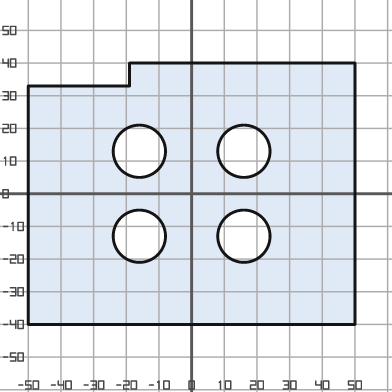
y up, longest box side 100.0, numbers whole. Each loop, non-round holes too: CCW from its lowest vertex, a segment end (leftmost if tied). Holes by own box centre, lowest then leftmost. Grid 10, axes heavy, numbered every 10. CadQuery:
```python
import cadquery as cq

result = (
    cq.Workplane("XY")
    .moveTo(-50.0, -40.0)
    .lineTo(50.0, -40.0)
    .lineTo(50.0, 40.0)
    .lineTo(-19.0, 40.0)
    .lineTo(-19.0, 33.0)
    .lineTo(-50.0, 33.0)
    .close()
    .moveTo(-16.0, -13.0)
    .circle(8.0)
    .moveTo(16.0, -13.0)
    .circle(8.0)
    .moveTo(-16.0, 13.0)
    .circle(8.0)
    .moveTo(16.0, 13.0)
    .circle(8.0)
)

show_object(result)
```